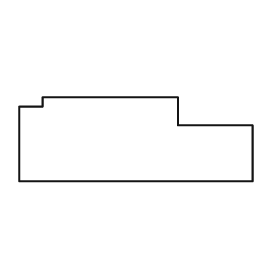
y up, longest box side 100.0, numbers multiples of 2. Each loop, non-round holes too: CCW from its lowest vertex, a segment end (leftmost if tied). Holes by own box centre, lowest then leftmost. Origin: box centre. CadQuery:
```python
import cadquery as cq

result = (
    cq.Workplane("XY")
    .moveTo(-50.0, -18.0)
    .lineTo(50.0, -18.0)
    .lineTo(50.0, 6.0)
    .lineTo(18.0, 6.0)
    .lineTo(18.0, 18.0)
    .lineTo(-40.0, 18.0)
    .lineTo(-40.0, 14.0)
    .lineTo(-50.0, 14.0)
    .close()
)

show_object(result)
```